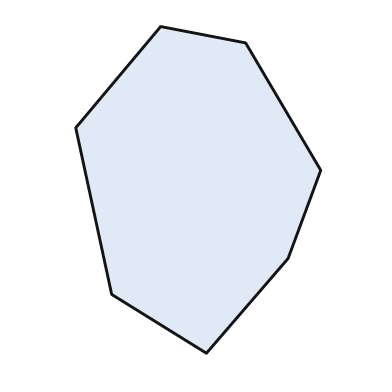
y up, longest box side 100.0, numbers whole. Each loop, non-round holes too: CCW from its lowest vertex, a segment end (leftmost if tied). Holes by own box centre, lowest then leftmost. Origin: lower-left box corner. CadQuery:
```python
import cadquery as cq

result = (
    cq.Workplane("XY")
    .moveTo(40.0, 0.0)
    .lineTo(65.0, 29.0)
    .lineTo(75.0, 56.0)
    .lineTo(52.0, 95.0)
    .lineTo(26.0, 100.0)
    .lineTo(0.0, 69.0)
    .lineTo(11.0, 18.0)
    .close()
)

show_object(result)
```